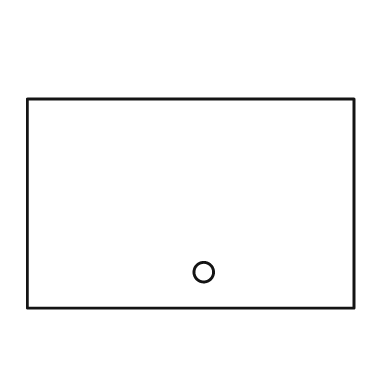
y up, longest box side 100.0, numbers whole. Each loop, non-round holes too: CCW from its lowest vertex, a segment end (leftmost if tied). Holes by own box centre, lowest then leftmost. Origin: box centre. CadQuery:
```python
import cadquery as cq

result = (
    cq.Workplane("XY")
    .moveTo(-50.0, -32.0)
    .lineTo(50.0, -32.0)
    .lineTo(50.0, 32.0)
    .lineTo(-50.0, 32.0)
    .close()
    .moveTo(4.0, -21.0)
    .circle(3.0)
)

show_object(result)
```